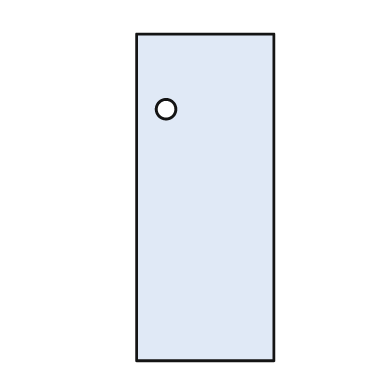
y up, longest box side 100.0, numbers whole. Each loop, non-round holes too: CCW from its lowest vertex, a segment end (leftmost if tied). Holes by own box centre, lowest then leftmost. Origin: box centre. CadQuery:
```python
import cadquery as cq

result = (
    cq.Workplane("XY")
    .moveTo(-21.0, -50.0)
    .lineTo(21.0, -50.0)
    .lineTo(21.0, 50.0)
    .lineTo(-21.0, 50.0)
    .close()
    .moveTo(-12.0, 27.0)
    .circle(3.0)
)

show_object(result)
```